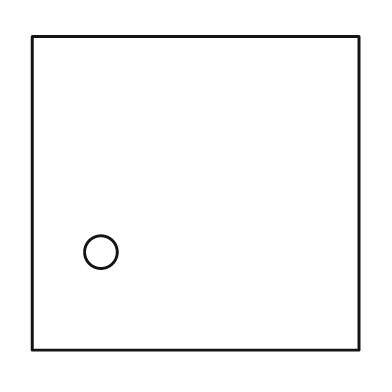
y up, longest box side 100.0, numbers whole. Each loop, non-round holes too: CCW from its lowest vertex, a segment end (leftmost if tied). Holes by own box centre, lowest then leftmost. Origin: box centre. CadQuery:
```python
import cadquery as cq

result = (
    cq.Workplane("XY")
    .moveTo(-50.0, -48.0)
    .lineTo(50.0, -48.0)
    .lineTo(50.0, 48.0)
    .lineTo(-50.0, 48.0)
    .close()
    .moveTo(-29.0, -18.0)
    .circle(5.0)
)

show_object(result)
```